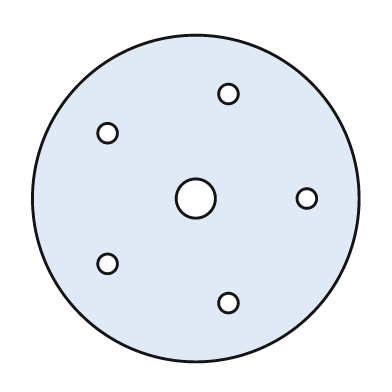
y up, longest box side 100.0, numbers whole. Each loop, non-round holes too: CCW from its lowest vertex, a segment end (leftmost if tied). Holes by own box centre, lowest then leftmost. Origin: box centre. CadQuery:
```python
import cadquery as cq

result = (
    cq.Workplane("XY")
    .moveTo(0.0, 0.0)
    .circle(50.0)
    .moveTo(10.0, -32.0)
    .circle(3.0)
    .moveTo(-27.0, -20.0)
    .circle(3.0)
    .moveTo(0.0, 0.0)
    .circle(6.0)
    .moveTo(34.0, 0.0)
    .circle(3.0)
    .moveTo(-27.0, 20.0)
    .circle(3.0)
    .moveTo(10.0, 32.0)
    .circle(3.0)
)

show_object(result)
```